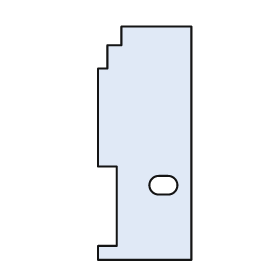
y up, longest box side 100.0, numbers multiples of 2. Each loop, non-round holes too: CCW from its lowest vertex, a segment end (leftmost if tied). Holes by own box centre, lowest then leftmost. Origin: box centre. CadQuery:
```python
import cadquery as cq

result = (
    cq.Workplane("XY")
    .moveTo(-20.0, -50.0)
    .lineTo(20.0, -50.0)
    .lineTo(20.0, 50.0)
    .lineTo(-10.0, 50.0)
    .lineTo(-10.0, 42.0)
    .lineTo(-16.0, 42.0)
    .lineTo(-16.0, 32.0)
    .lineTo(-20.0, 32.0)
    .lineTo(-20.0, -10.0)
    .lineTo(-12.0, -10.0)
    .lineTo(-12.0, -44.0)
    .lineTo(-20.0, -44.0)
    .close()
    .moveTo(6.0, -22.0)
    .lineTo(10.0, -22.0)
    .threePointArc((14.0, -18.0), (10.0, -14.0))
    .lineTo(6.0, -14.0)
    .threePointArc((2.0, -18.0), (6.0, -22.0))
    .close()
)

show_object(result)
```